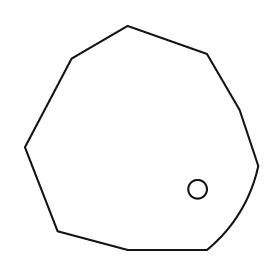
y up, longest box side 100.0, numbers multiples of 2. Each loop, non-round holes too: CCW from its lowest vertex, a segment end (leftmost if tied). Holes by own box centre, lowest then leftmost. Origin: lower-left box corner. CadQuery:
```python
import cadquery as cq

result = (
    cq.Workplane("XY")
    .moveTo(44.0, 0.0)
    .lineTo(78.0, 0.0)
    .threePointArc((92.0, 16.0), (100.0, 36.0))
    .lineTo(92.0, 60.0)
    .lineTo(78.0, 84.0)
    .lineTo(44.0, 96.0)
    .lineTo(20.0, 82.0)
    .lineTo(0.0, 44.0)
    .lineTo(14.0, 8.0)
    .close()
    .moveTo(74.0, 26.0)
    .circle(4.0)
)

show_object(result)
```